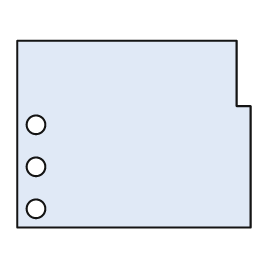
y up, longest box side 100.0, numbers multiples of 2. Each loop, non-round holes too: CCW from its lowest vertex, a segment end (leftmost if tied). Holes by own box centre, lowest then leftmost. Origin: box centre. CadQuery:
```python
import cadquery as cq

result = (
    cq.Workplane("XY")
    .moveTo(-50.0, -40.0)
    .lineTo(50.0, -40.0)
    .lineTo(50.0, 12.0)
    .lineTo(44.0, 12.0)
    .lineTo(44.0, 40.0)
    .lineTo(-50.0, 40.0)
    .close()
    .moveTo(-42.0, -32.0)
    .circle(4.0)
    .moveTo(-42.0, -14.0)
    .circle(4.0)
    .moveTo(-42.0, 4.0)
    .circle(4.0)
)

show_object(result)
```